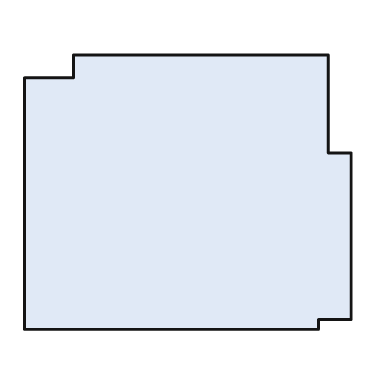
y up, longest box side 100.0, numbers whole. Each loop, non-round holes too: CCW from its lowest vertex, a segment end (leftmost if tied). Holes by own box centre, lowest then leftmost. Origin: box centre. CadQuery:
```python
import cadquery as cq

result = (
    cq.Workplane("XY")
    .moveTo(-50.0, -42.0)
    .lineTo(40.0, -42.0)
    .lineTo(40.0, -39.0)
    .lineTo(50.0, -39.0)
    .lineTo(50.0, 12.0)
    .lineTo(43.0, 12.0)
    .lineTo(43.0, 42.0)
    .lineTo(-35.0, 42.0)
    .lineTo(-35.0, 35.0)
    .lineTo(-50.0, 35.0)
    .close()
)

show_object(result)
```